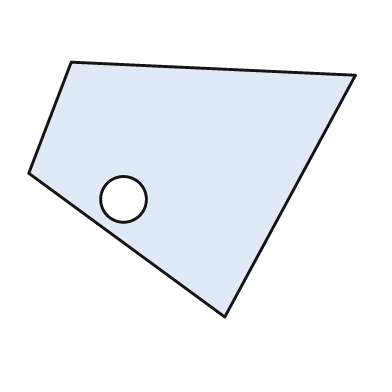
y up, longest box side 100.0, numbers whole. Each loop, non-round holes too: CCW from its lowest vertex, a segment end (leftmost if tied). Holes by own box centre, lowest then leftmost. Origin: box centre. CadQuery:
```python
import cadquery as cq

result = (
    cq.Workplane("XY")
    .moveTo(10.0, -39.0)
    .lineTo(50.0, 35.0)
    .lineTo(-37.0, 39.0)
    .lineTo(-50.0, 5.0)
    .close()
    .moveTo(-21.0, -3.0)
    .circle(7.0)
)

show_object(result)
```